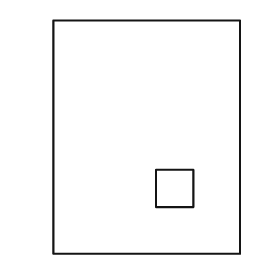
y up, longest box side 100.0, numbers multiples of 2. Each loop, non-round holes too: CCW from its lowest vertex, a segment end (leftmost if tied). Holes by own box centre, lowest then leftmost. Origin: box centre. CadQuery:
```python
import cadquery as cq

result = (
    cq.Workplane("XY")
    .moveTo(-40.0, -50.0)
    .lineTo(40.0, -50.0)
    .lineTo(40.0, 50.0)
    .lineTo(-40.0, 50.0)
    .close()
    .moveTo(4.0, -30.0)
    .lineTo(20.0, -30.0)
    .lineTo(20.0, -14.0)
    .lineTo(4.0, -14.0)
    .close()
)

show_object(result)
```